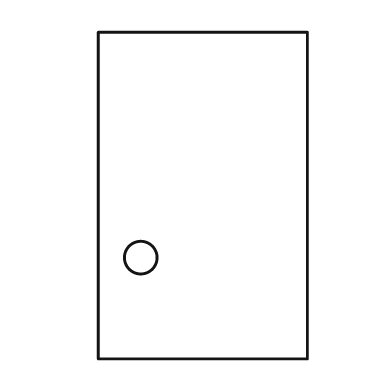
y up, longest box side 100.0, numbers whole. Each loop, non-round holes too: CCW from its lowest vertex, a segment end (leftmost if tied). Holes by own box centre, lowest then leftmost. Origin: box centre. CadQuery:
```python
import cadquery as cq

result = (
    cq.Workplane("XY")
    .moveTo(-32.0, -50.0)
    .lineTo(32.0, -50.0)
    .lineTo(32.0, 50.0)
    .lineTo(-32.0, 50.0)
    .close()
    .moveTo(-19.0, -19.0)
    .circle(5.0)
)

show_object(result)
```